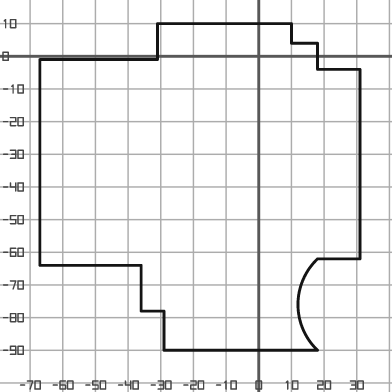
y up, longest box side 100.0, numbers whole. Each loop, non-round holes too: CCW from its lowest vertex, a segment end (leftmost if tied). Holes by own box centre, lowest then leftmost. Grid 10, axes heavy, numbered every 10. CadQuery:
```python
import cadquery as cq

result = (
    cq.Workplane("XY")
    .moveTo(-29.0, -90.0)
    .lineTo(18.0, -90.0)
    .threePointArc((12.0, -76.0), (18.0, -62.0))
    .lineTo(31.0, -62.0)
    .lineTo(31.0, -4.0)
    .lineTo(18.0, -4.0)
    .lineTo(18.0, 4.0)
    .lineTo(10.0, 4.0)
    .lineTo(10.0, 10.0)
    .lineTo(-31.0, 10.0)
    .lineTo(-31.0, -1.0)
    .lineTo(-67.0, -1.0)
    .lineTo(-67.0, -64.0)
    .lineTo(-36.0, -64.0)
    .lineTo(-36.0, -78.0)
    .lineTo(-29.0, -78.0)
    .close()
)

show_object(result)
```